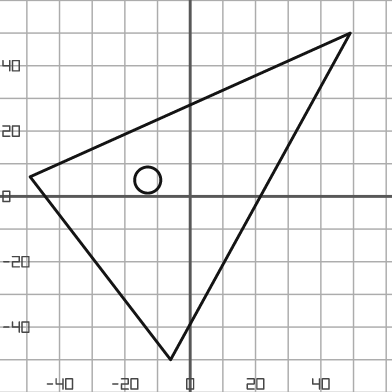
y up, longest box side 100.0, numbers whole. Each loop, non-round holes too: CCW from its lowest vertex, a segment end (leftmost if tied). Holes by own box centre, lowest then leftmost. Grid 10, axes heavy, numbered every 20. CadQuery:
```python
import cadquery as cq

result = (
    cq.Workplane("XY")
    .moveTo(-6.0, -50.0)
    .lineTo(49.0, 50.0)
    .lineTo(-49.0, 6.0)
    .close()
    .moveTo(-13.0, 5.0)
    .circle(4.0)
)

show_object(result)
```